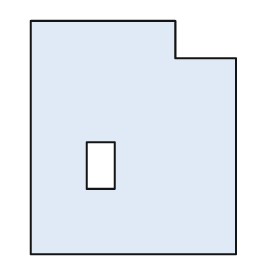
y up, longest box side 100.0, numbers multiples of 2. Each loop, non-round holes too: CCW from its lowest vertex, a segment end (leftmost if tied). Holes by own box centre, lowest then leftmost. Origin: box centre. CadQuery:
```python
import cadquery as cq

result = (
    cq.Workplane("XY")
    .moveTo(-44.0, -50.0)
    .lineTo(44.0, -50.0)
    .lineTo(44.0, 34.0)
    .lineTo(18.0, 34.0)
    .lineTo(18.0, 50.0)
    .lineTo(-44.0, 50.0)
    .close()
    .moveTo(-20.0, -22.0)
    .lineTo(-8.0, -22.0)
    .lineTo(-8.0, -2.0)
    .lineTo(-20.0, -2.0)
    .close()
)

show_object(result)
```